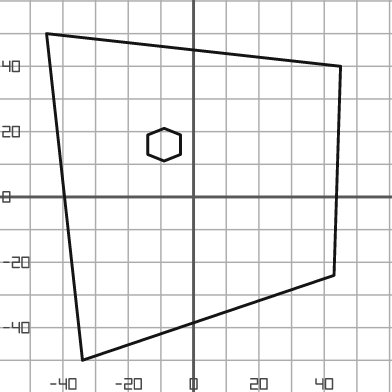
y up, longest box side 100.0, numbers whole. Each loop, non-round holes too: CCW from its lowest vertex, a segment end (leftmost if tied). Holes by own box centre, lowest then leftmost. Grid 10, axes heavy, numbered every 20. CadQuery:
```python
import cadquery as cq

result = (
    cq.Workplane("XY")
    .moveTo(-34.0, -50.0)
    .lineTo(43.0, -24.0)
    .lineTo(45.0, 40.0)
    .lineTo(-45.0, 50.0)
    .close()
    .moveTo(-9.0, 11.0)
    .lineTo(-4.0, 13.0)
    .lineTo(-4.0, 19.0)
    .lineTo(-9.0, 21.0)
    .lineTo(-14.0, 19.0)
    .lineTo(-14.0, 13.0)
    .close()
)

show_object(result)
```